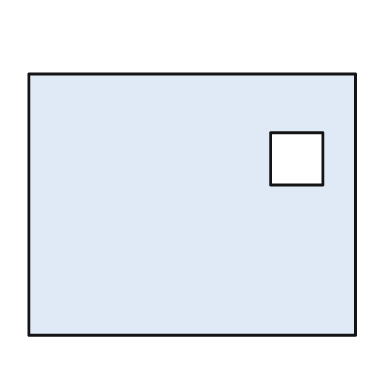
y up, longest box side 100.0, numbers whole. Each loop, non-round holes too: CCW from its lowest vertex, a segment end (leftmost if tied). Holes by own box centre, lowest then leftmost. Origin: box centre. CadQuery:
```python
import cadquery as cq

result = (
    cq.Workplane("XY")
    .moveTo(-50.0, -40.0)
    .lineTo(50.0, -40.0)
    .lineTo(50.0, 40.0)
    .lineTo(-50.0, 40.0)
    .close()
    .moveTo(24.0, 6.0)
    .lineTo(40.0, 6.0)
    .lineTo(40.0, 22.0)
    .lineTo(24.0, 22.0)
    .close()
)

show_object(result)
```